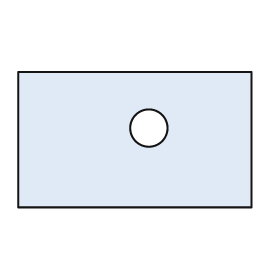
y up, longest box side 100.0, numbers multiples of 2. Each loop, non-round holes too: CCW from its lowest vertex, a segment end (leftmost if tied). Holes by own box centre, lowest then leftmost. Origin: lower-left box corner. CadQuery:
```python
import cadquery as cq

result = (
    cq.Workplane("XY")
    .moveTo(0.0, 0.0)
    .lineTo(100.0, 0.0)
    .lineTo(100.0, 58.0)
    .lineTo(0.0, 58.0)
    .close()
    .moveTo(56.0, 34.0)
    .circle(8.0)
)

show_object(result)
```